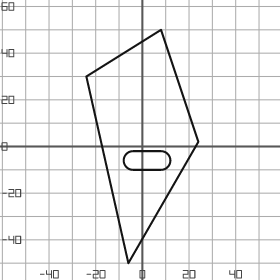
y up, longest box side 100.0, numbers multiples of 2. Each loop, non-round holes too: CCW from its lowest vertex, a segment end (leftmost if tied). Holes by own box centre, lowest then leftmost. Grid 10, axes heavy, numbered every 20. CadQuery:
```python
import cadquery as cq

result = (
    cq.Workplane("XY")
    .moveTo(-6.0, -50.0)
    .lineTo(24.0, 2.0)
    .lineTo(8.0, 50.0)
    .lineTo(-24.0, 30.0)
    .close()
    .moveTo(-4.0, -10.0)
    .lineTo(8.0, -10.0)
    .threePointArc((12.0, -6.0), (8.0, -2.0))
    .lineTo(-4.0, -2.0)
    .threePointArc((-8.0, -6.0), (-4.0, -10.0))
    .close()
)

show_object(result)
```